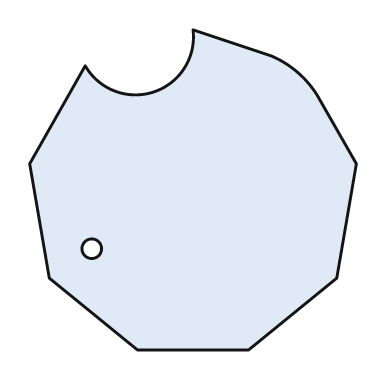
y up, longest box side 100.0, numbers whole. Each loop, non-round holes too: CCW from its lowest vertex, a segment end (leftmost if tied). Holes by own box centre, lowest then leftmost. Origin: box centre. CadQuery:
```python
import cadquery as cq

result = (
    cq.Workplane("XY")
    .moveTo(-17.0, -49.0)
    .lineTo(17.0, -49.0)
    .lineTo(44.0, -27.0)
    .lineTo(50.0, 8.0)
    .lineTo(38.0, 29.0)
    .threePointArc((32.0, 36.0), (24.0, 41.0))
    .lineTo(0.0, 49.0)
    .threePointArc((-12.0, 30.0), (-33.0, 38.0))
    .lineTo(-50.0, 8.0)
    .lineTo(-44.0, -27.0)
    .close()
    .moveTo(-31.0, -18.0)
    .circle(3.0)
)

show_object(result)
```